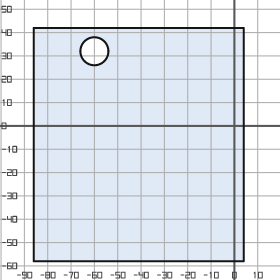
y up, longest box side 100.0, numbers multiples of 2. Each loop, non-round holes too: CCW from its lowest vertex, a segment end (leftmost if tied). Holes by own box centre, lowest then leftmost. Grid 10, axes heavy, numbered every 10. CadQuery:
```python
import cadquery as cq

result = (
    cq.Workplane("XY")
    .moveTo(-86.0, -58.0)
    .lineTo(4.0, -58.0)
    .lineTo(4.0, 42.0)
    .lineTo(-86.0, 42.0)
    .close()
    .moveTo(-60.0, 32.0)
    .circle(6.0)
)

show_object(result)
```